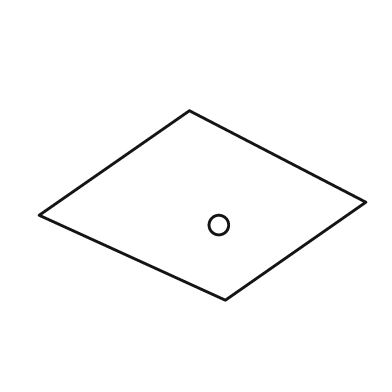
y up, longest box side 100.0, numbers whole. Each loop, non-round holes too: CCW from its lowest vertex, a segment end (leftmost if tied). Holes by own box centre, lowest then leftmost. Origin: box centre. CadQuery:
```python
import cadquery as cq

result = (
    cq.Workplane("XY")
    .moveTo(7.0, -29.0)
    .lineTo(50.0, 1.0)
    .lineTo(-4.0, 29.0)
    .lineTo(-50.0, -3.0)
    .close()
    .moveTo(5.0, -6.0)
    .circle(3.0)
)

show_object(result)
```